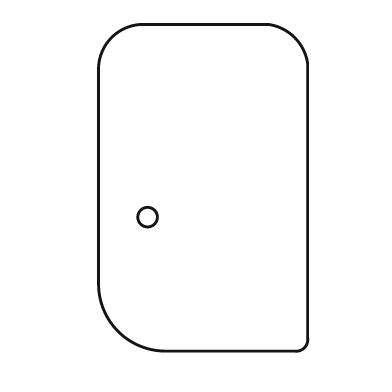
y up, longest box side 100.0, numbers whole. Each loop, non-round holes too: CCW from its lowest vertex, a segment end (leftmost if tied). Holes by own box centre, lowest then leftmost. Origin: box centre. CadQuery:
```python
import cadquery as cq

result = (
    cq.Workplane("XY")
    .moveTo(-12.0, -50.0)
    .lineTo(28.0, -50.0)
    .threePointArc((31.0, -49.0), (32.0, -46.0))
    .lineTo(32.0, 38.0)
    .threePointArc((28.0, 46.0), (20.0, 50.0))
    .lineTo(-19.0, 50.0)
    .threePointArc((-28.0, 46.0), (-32.0, 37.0))
    .lineTo(-32.0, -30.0)
    .threePointArc((-26.0, -44.0), (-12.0, -50.0))
    .close()
    .moveTo(-17.0, -9.0)
    .circle(3.0)
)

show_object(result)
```